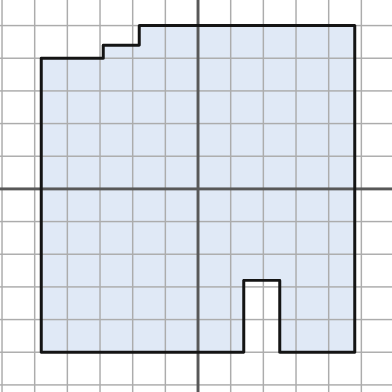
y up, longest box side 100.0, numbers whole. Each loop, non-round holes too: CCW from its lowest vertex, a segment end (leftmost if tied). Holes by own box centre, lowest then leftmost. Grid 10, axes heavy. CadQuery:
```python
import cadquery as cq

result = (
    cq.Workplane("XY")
    .moveTo(-48.0, -50.0)
    .lineTo(14.0, -50.0)
    .lineTo(14.0, -28.0)
    .lineTo(25.0, -28.0)
    .lineTo(25.0, -50.0)
    .lineTo(48.0, -50.0)
    .lineTo(48.0, 50.0)
    .lineTo(-18.0, 50.0)
    .lineTo(-18.0, 44.0)
    .lineTo(-29.0, 44.0)
    .lineTo(-29.0, 40.0)
    .lineTo(-48.0, 40.0)
    .close()
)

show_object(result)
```